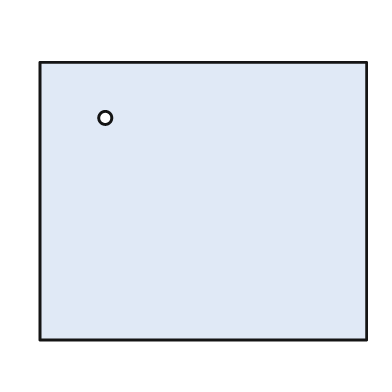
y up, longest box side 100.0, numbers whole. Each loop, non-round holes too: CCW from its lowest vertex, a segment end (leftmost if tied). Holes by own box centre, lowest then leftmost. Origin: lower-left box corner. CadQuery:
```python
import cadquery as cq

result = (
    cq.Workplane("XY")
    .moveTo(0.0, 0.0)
    .lineTo(100.0, 0.0)
    .lineTo(100.0, 85.0)
    .lineTo(0.0, 85.0)
    .close()
    .moveTo(20.0, 68.0)
    .circle(2.0)
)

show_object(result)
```